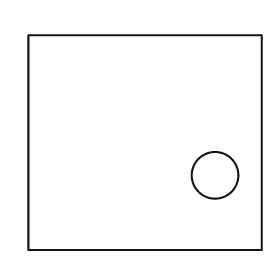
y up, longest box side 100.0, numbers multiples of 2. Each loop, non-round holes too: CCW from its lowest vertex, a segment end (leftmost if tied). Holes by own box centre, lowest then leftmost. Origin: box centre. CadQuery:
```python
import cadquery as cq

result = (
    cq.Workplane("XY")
    .moveTo(-50.0, -46.0)
    .lineTo(50.0, -46.0)
    .lineTo(50.0, 46.0)
    .lineTo(-50.0, 46.0)
    .close()
    .moveTo(30.0, -14.0)
    .circle(10.0)
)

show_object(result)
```